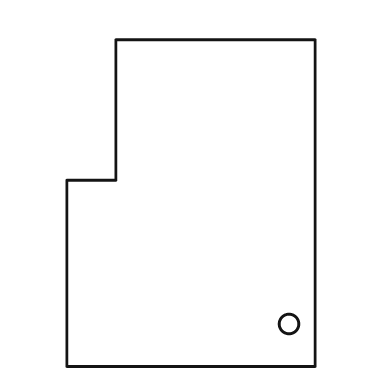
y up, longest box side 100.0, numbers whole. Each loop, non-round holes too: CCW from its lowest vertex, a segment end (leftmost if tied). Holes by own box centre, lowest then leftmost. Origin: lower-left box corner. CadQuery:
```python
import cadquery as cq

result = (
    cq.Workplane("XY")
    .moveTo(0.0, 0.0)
    .lineTo(76.0, 0.0)
    .lineTo(76.0, 100.0)
    .lineTo(15.0, 100.0)
    .lineTo(15.0, 57.0)
    .lineTo(0.0, 57.0)
    .close()
    .moveTo(68.0, 13.0)
    .circle(3.0)
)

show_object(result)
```